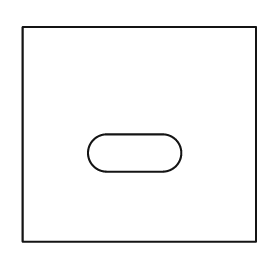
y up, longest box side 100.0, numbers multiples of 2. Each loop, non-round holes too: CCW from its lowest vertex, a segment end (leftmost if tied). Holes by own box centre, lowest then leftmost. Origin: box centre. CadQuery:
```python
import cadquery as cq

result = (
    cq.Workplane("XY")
    .moveTo(-50.0, -46.0)
    .lineTo(50.0, -46.0)
    .lineTo(50.0, 46.0)
    .lineTo(-50.0, 46.0)
    .close()
    .moveTo(-14.0, -16.0)
    .lineTo(10.0, -16.0)
    .threePointArc((18.0, -8.0), (10.0, 0.0))
    .lineTo(-14.0, 0.0)
    .threePointArc((-22.0, -8.0), (-14.0, -16.0))
    .close()
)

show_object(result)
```